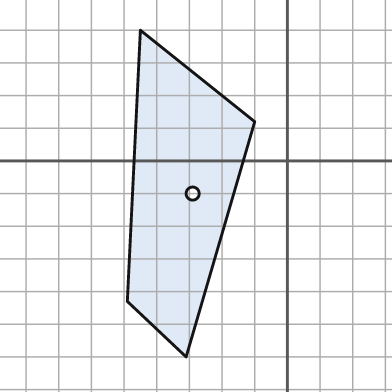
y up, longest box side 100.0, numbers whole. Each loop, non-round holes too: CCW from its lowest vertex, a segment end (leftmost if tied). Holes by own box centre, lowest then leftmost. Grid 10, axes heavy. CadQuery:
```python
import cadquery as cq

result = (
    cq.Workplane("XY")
    .moveTo(-31.0, -60.0)
    .lineTo(-10.0, 12.0)
    .lineTo(-45.0, 40.0)
    .lineTo(-49.0, -43.0)
    .close()
    .moveTo(-29.0, -10.0)
    .circle(2.0)
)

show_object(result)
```